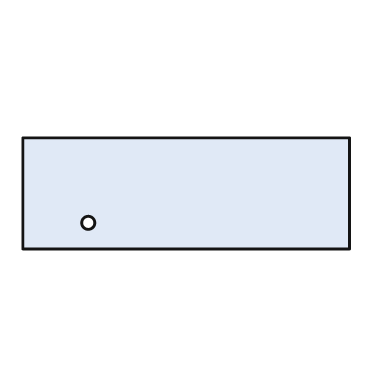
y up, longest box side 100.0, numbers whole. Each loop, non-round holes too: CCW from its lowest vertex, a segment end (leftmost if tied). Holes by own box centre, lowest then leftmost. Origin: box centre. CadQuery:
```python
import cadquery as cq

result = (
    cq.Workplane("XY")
    .moveTo(-50.0, -17.0)
    .lineTo(50.0, -17.0)
    .lineTo(50.0, 17.0)
    .lineTo(-50.0, 17.0)
    .close()
    .moveTo(-30.0, -9.0)
    .circle(2.0)
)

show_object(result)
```